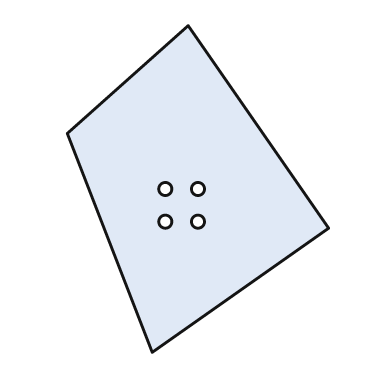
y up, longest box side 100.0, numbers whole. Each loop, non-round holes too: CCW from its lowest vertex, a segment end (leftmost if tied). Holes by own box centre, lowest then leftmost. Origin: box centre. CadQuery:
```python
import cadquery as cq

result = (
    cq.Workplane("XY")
    .moveTo(-14.0, -50.0)
    .lineTo(40.0, -12.0)
    .lineTo(-3.0, 50.0)
    .lineTo(-40.0, 17.0)
    .close()
    .moveTo(-10.0, -10.0)
    .circle(2.0)
    .moveTo(0.0, -10.0)
    .circle(2.0)
    .moveTo(-10.0, 0.0)
    .circle(2.0)
    .moveTo(0.0, 0.0)
    .circle(2.0)
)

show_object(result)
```